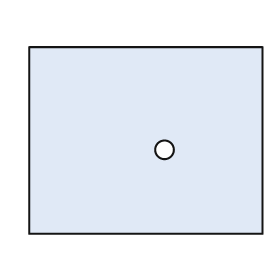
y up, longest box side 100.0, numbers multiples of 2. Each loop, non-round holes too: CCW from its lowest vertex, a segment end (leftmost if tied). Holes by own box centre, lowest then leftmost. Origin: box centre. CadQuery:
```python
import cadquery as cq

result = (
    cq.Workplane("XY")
    .moveTo(-50.0, -40.0)
    .lineTo(50.0, -40.0)
    .lineTo(50.0, 40.0)
    .lineTo(-50.0, 40.0)
    .close()
    .moveTo(8.0, -4.0)
    .circle(4.0)
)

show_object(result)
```